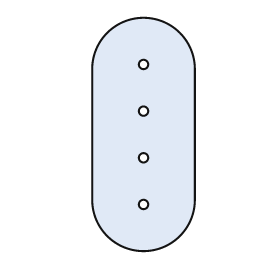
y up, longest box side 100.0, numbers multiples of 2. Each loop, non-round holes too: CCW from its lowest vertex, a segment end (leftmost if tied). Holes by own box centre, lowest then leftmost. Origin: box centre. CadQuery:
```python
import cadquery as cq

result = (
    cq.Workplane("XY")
    .moveTo(-22.0, -28.0)
    .threePointArc((0.0, -50.0), (22.0, -28.0))
    .lineTo(22.0, 28.0)
    .threePointArc((0.0, 50.0), (-22.0, 28.0))
    .close()
    .moveTo(0.0, -30.0)
    .circle(2.0)
    .moveTo(0.0, -10.0)
    .circle(2.0)
    .moveTo(0.0, 10.0)
    .circle(2.0)
    .moveTo(0.0, 30.0)
    .circle(2.0)
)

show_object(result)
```